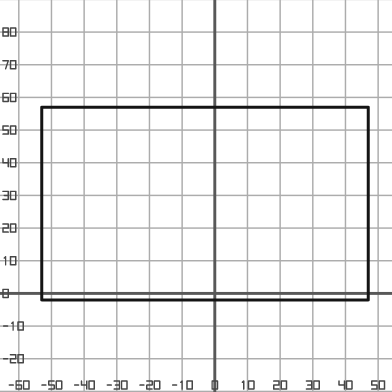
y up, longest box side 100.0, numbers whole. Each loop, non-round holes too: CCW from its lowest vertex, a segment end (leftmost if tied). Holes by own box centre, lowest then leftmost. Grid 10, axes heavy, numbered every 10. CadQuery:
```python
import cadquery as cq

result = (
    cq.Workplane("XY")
    .moveTo(-53.0, -2.0)
    .lineTo(47.0, -2.0)
    .lineTo(47.0, 57.0)
    .lineTo(-53.0, 57.0)
    .close()
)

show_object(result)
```